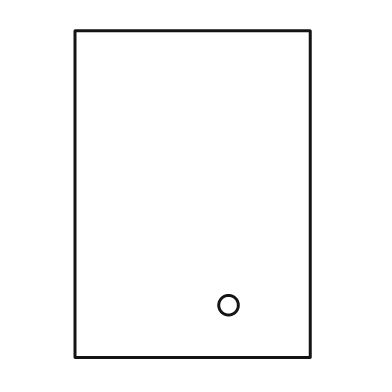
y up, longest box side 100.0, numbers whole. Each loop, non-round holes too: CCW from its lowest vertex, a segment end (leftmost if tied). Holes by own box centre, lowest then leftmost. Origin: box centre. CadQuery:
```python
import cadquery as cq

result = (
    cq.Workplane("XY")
    .moveTo(-36.0, -50.0)
    .lineTo(36.0, -50.0)
    .lineTo(36.0, 50.0)
    .lineTo(-36.0, 50.0)
    .close()
    .moveTo(11.0, -34.0)
    .circle(3.0)
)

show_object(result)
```